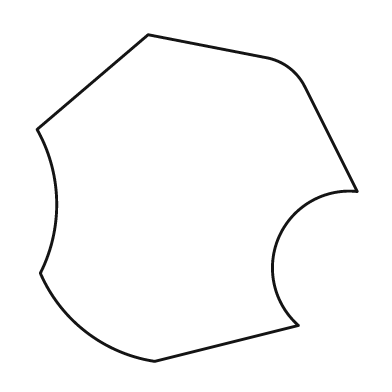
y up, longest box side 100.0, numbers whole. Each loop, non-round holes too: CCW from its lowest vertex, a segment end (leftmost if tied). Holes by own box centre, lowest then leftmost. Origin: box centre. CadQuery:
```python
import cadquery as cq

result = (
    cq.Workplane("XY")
    .moveTo(-13.0, -50.0)
    .lineTo(31.0, -39.0)
    .threePointArc((25.0, -12.0), (49.0, 2.0))
    .lineTo(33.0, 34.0)
    .threePointArc((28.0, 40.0), (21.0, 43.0))
    .lineTo(-15.0, 50.0)
    .lineTo(-49.0, 21.0)
    .threePointArc((-43.0, -1.0), (-48.0, -23.0))
    .threePointArc((-34.0, -41.0), (-13.0, -50.0))
    .close()
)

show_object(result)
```